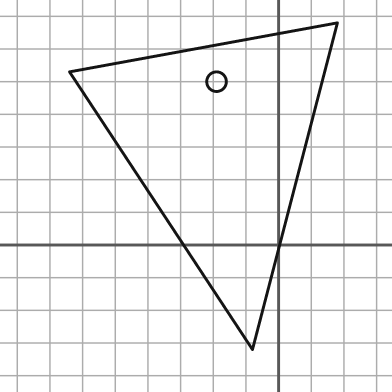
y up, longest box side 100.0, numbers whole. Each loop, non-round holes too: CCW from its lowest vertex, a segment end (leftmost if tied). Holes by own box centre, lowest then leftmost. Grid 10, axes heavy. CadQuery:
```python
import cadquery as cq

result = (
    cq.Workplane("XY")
    .moveTo(-8.0, -32.0)
    .lineTo(18.0, 68.0)
    .lineTo(-64.0, 53.0)
    .close()
    .moveTo(-19.0, 50.0)
    .circle(3.0)
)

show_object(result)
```